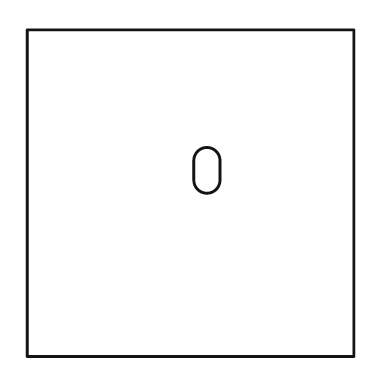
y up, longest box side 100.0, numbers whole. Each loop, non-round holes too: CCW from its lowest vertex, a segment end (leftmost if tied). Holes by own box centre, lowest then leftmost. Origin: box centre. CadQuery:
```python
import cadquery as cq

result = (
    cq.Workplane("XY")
    .moveTo(-50.0, -50.0)
    .lineTo(50.0, -50.0)
    .lineTo(50.0, 50.0)
    .lineTo(-50.0, 50.0)
    .close()
    .moveTo(1.0, 4.0)
    .threePointArc((5.0, 0.0), (9.0, 4.0))
    .lineTo(9.0, 10.0)
    .threePointArc((5.0, 14.0), (1.0, 10.0))
    .close()
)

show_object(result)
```